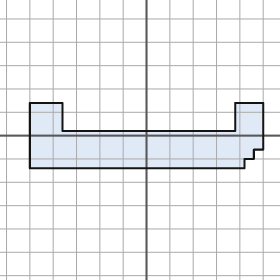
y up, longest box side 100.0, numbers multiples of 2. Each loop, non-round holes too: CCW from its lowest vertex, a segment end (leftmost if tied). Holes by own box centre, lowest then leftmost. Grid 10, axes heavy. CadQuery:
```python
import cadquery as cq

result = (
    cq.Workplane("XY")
    .moveTo(-50.0, -14.0)
    .lineTo(42.0, -14.0)
    .lineTo(42.0, -10.0)
    .lineTo(46.0, -10.0)
    .lineTo(46.0, -6.0)
    .lineTo(50.0, -6.0)
    .lineTo(50.0, 14.0)
    .lineTo(38.0, 14.0)
    .lineTo(38.0, 2.0)
    .lineTo(-36.0, 2.0)
    .lineTo(-36.0, 14.0)
    .lineTo(-50.0, 14.0)
    .close()
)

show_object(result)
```